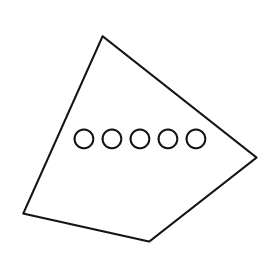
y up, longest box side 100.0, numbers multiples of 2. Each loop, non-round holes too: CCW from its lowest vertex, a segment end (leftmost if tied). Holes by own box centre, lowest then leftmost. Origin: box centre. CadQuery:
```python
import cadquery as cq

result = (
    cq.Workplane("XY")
    .moveTo(4.0, -44.0)
    .lineTo(50.0, -8.0)
    .lineTo(-16.0, 44.0)
    .lineTo(-50.0, -32.0)
    .close()
    .moveTo(-24.0, 0.0)
    .circle(4.0)
    .moveTo(-12.0, 0.0)
    .circle(4.0)
    .moveTo(0.0, 0.0)
    .circle(4.0)
    .moveTo(12.0, 0.0)
    .circle(4.0)
    .moveTo(24.0, 0.0)
    .circle(4.0)
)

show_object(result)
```